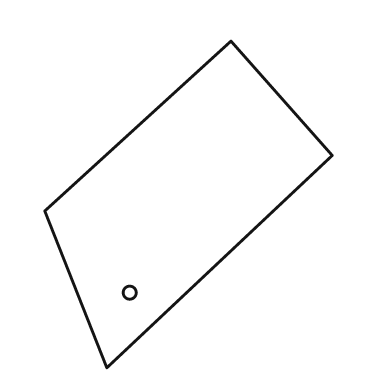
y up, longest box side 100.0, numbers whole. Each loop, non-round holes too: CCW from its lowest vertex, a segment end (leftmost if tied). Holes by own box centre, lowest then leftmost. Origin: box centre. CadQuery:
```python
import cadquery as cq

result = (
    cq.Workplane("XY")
    .moveTo(-25.0, -50.0)
    .lineTo(44.0, 15.0)
    .lineTo(13.0, 50.0)
    .lineTo(-44.0, -2.0)
    .close()
    .moveTo(-18.0, -27.0)
    .circle(2.0)
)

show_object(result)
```